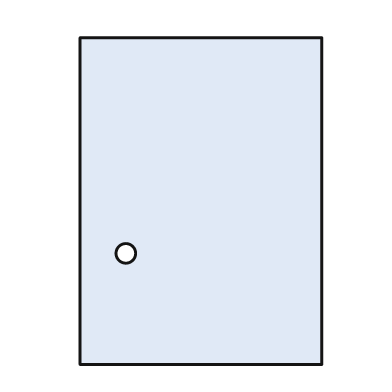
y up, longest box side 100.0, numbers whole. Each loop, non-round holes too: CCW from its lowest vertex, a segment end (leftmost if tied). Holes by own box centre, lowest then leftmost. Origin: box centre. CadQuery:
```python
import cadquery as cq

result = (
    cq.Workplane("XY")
    .moveTo(-37.0, -50.0)
    .lineTo(37.0, -50.0)
    .lineTo(37.0, 50.0)
    .lineTo(-37.0, 50.0)
    .close()
    .moveTo(-23.0, -16.0)
    .circle(3.0)
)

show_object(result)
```